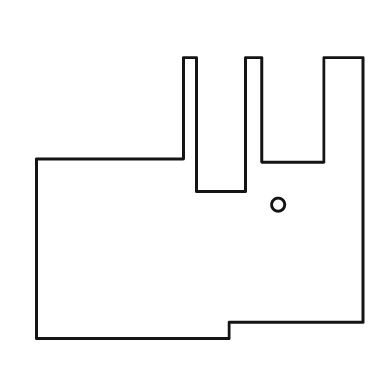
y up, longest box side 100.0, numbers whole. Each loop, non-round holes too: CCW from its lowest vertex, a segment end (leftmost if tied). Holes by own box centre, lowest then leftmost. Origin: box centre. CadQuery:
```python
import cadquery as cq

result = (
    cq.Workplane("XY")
    .moveTo(-50.0, -43.0)
    .lineTo(9.0, -43.0)
    .lineTo(9.0, -38.0)
    .lineTo(50.0, -38.0)
    .lineTo(50.0, 43.0)
    .lineTo(38.0, 43.0)
    .lineTo(38.0, 11.0)
    .lineTo(19.0, 11.0)
    .lineTo(19.0, 43.0)
    .lineTo(14.0, 43.0)
    .lineTo(14.0, 2.0)
    .lineTo(-1.0, 2.0)
    .lineTo(-1.0, 43.0)
    .lineTo(-5.0, 43.0)
    .lineTo(-5.0, 12.0)
    .lineTo(-50.0, 12.0)
    .close()
    .moveTo(24.0, -2.0)
    .circle(2.0)
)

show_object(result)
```